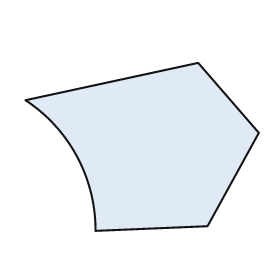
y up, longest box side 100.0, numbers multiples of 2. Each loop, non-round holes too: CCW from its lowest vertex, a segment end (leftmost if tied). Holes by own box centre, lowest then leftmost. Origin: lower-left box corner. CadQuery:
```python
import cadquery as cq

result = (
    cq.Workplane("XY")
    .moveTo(30.0, 0.0)
    .lineTo(78.0, 2.0)
    .lineTo(100.0, 42.0)
    .lineTo(74.0, 72.0)
    .lineTo(0.0, 56.0)
    .threePointArc((22.0, 32.0), (30.0, 0.0))
    .close()
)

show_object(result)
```